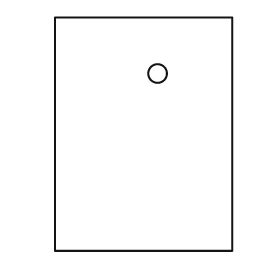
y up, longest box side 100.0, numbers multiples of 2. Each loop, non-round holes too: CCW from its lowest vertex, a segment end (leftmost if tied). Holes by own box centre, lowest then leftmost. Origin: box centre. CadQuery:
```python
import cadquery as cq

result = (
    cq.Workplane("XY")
    .moveTo(-38.0, -50.0)
    .lineTo(38.0, -50.0)
    .lineTo(38.0, 50.0)
    .lineTo(-38.0, 50.0)
    .close()
    .moveTo(6.0, 26.0)
    .circle(4.0)
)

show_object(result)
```